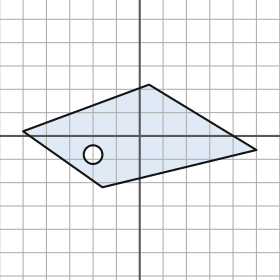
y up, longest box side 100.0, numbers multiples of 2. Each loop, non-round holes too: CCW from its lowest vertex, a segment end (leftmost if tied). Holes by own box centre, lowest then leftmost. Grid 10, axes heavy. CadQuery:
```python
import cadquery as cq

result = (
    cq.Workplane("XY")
    .moveTo(-16.0, -22.0)
    .lineTo(50.0, -6.0)
    .lineTo(4.0, 22.0)
    .lineTo(-50.0, 2.0)
    .close()
    .moveTo(-20.0, -8.0)
    .circle(4.0)
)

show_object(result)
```